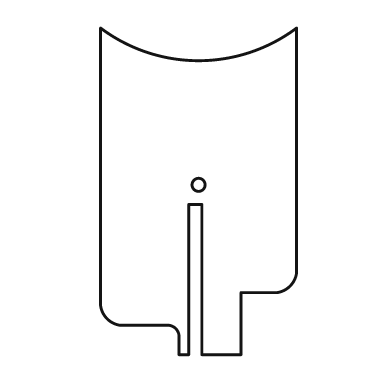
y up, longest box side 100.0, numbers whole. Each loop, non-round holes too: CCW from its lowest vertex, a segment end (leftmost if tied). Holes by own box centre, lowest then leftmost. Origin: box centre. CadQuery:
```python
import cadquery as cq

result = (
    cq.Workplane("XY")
    .moveTo(-6.0, -50.0)
    .lineTo(-3.0, -50.0)
    .lineTo(-3.0, -4.0)
    .lineTo(1.0, -4.0)
    .lineTo(1.0, -50.0)
    .lineTo(13.0, -50.0)
    .lineTo(13.0, -31.0)
    .lineTo(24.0, -31.0)
    .threePointArc((28.0, -29.0), (30.0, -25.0))
    .lineTo(30.0, 50.0)
    .threePointArc((0.0, 40.0), (-30.0, 50.0))
    .lineTo(-30.0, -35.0)
    .threePointArc((-28.0, -39.0), (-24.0, -41.0))
    .lineTo(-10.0, -41.0)
    .threePointArc((-7.0, -42.0), (-6.0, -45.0))
    .close()
    .moveTo(0.0, 2.0)
    .circle(2.0)
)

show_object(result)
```